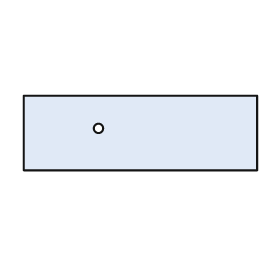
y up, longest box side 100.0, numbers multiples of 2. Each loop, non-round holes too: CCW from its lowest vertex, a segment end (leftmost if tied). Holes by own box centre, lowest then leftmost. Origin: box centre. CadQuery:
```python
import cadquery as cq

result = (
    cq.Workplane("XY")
    .moveTo(-50.0, -16.0)
    .lineTo(50.0, -16.0)
    .lineTo(50.0, 16.0)
    .lineTo(-50.0, 16.0)
    .close()
    .moveTo(-18.0, 2.0)
    .circle(2.0)
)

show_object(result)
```